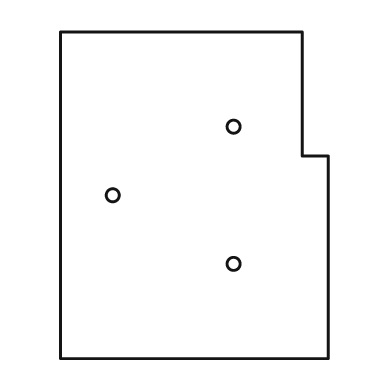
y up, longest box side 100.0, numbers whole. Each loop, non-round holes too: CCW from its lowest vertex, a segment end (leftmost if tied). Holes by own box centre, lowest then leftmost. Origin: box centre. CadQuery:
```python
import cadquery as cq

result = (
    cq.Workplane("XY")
    .moveTo(-41.0, -50.0)
    .lineTo(41.0, -50.0)
    .lineTo(41.0, 12.0)
    .lineTo(33.0, 12.0)
    .lineTo(33.0, 50.0)
    .lineTo(-41.0, 50.0)
    .close()
    .moveTo(12.0, -21.0)
    .circle(2.0)
    .moveTo(-25.0, 0.0)
    .circle(2.0)
    .moveTo(12.0, 21.0)
    .circle(2.0)
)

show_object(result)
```